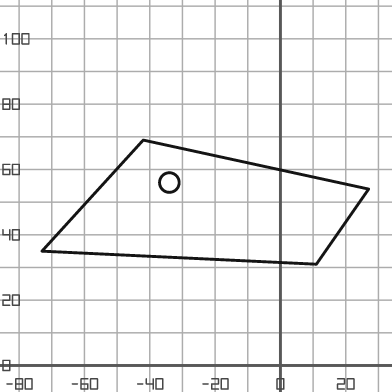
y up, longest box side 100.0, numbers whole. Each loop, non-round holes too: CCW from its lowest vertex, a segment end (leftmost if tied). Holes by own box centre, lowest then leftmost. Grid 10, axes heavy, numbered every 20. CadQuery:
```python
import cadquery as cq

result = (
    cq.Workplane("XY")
    .moveTo(11.0, 31.0)
    .lineTo(27.0, 54.0)
    .lineTo(-42.0, 69.0)
    .lineTo(-73.0, 35.0)
    .close()
    .moveTo(-34.0, 56.0)
    .circle(3.0)
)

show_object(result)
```